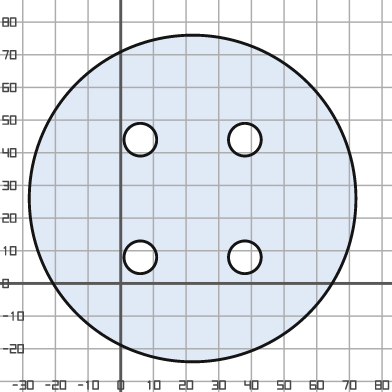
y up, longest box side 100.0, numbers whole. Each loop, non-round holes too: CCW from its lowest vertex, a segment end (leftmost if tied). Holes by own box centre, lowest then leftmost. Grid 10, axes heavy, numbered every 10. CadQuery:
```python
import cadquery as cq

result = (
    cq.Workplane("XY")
    .moveTo(22.0, 26.0)
    .circle(50.0)
    .moveTo(6.0, 8.0)
    .circle(5.0)
    .moveTo(38.0, 8.0)
    .circle(5.0)
    .moveTo(6.0, 44.0)
    .circle(5.0)
    .moveTo(38.0, 44.0)
    .circle(5.0)
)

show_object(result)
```